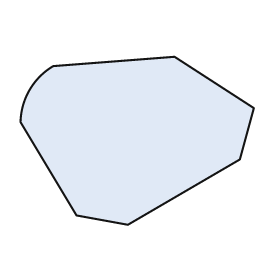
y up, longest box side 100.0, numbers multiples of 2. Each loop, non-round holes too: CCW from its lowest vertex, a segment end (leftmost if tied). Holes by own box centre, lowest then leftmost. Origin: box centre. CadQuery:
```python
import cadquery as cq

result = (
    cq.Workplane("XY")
    .moveTo(-4.0, -36.0)
    .lineTo(44.0, -8.0)
    .lineTo(50.0, 14.0)
    .lineTo(16.0, 36.0)
    .lineTo(-36.0, 32.0)
    .threePointArc((-46.0, 22.0), (-50.0, 8.0))
    .lineTo(-26.0, -32.0)
    .close()
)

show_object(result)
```